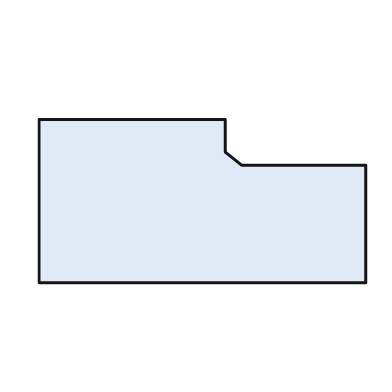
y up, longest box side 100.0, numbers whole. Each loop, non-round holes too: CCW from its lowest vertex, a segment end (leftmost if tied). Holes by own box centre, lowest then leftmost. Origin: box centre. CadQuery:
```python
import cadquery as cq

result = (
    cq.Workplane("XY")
    .moveTo(-50.0, -25.0)
    .lineTo(50.0, -25.0)
    .lineTo(50.0, 11.0)
    .lineTo(12.0, 11.0)
    .lineTo(7.0, 15.0)
    .lineTo(7.0, 25.0)
    .lineTo(-50.0, 25.0)
    .close()
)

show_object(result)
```